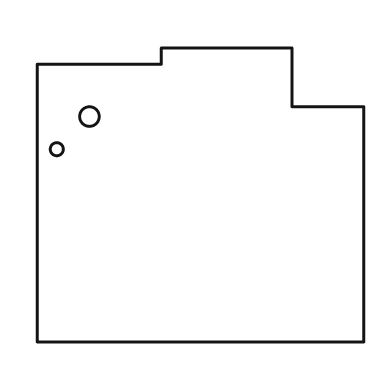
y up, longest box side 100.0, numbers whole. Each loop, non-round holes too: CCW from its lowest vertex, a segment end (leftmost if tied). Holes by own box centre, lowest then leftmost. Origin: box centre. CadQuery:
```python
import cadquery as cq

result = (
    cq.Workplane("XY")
    .moveTo(-50.0, -45.0)
    .lineTo(50.0, -45.0)
    .lineTo(50.0, 27.0)
    .lineTo(28.0, 27.0)
    .lineTo(28.0, 45.0)
    .lineTo(-12.0, 45.0)
    .lineTo(-12.0, 40.0)
    .lineTo(-50.0, 40.0)
    .close()
    .moveTo(-44.0, 14.0)
    .circle(2.0)
    .moveTo(-34.0, 24.0)
    .circle(3.0)
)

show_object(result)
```